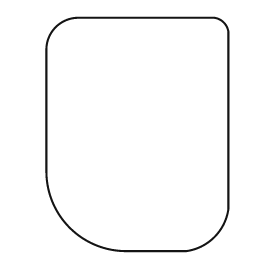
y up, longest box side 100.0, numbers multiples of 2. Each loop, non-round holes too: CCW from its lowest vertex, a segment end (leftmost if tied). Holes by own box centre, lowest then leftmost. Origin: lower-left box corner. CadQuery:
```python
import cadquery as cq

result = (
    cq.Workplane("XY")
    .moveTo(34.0, 0.0)
    .lineTo(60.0, 0.0)
    .threePointArc((72.0, 6.0), (78.0, 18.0))
    .lineTo(78.0, 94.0)
    .threePointArc((76.0, 98.0), (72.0, 100.0))
    .lineTo(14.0, 100.0)
    .threePointArc((4.0, 96.0), (0.0, 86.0))
    .lineTo(0.0, 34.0)
    .threePointArc((10.0, 10.0), (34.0, 0.0))
    .close()
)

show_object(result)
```